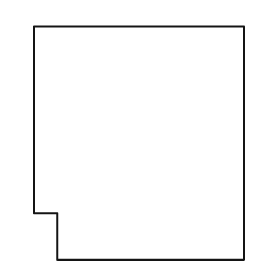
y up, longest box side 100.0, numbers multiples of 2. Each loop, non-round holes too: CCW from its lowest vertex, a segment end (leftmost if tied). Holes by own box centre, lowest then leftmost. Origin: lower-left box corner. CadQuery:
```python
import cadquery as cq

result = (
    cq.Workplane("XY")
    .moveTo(10.0, 0.0)
    .lineTo(90.0, 0.0)
    .lineTo(90.0, 100.0)
    .lineTo(0.0, 100.0)
    .lineTo(0.0, 20.0)
    .lineTo(10.0, 20.0)
    .close()
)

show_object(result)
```